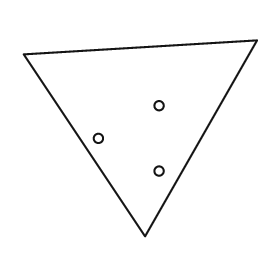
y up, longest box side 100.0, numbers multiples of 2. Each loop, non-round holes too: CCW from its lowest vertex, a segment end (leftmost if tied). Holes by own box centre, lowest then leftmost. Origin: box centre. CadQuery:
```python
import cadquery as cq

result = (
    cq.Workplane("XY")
    .moveTo(2.0, -42.0)
    .lineTo(50.0, 42.0)
    .lineTo(-50.0, 36.0)
    .close()
    .moveTo(8.0, -14.0)
    .circle(2.0)
    .moveTo(-18.0, 0.0)
    .circle(2.0)
    .moveTo(8.0, 14.0)
    .circle(2.0)
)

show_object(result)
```